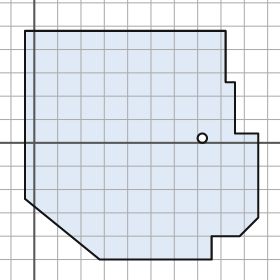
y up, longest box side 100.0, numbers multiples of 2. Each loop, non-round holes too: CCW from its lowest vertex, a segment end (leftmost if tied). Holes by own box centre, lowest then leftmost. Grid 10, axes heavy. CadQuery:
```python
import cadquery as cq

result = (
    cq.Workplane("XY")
    .moveTo(28.0, -50.0)
    .lineTo(76.0, -50.0)
    .lineTo(76.0, -40.0)
    .lineTo(88.0, -40.0)
    .lineTo(96.0, -32.0)
    .lineTo(96.0, 4.0)
    .lineTo(86.0, 4.0)
    .lineTo(86.0, 26.0)
    .lineTo(82.0, 26.0)
    .lineTo(82.0, 48.0)
    .lineTo(-4.0, 48.0)
    .lineTo(-4.0, -24.0)
    .close()
    .moveTo(72.0, 2.0)
    .circle(2.0)
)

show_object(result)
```